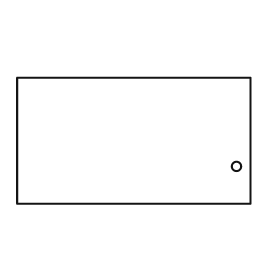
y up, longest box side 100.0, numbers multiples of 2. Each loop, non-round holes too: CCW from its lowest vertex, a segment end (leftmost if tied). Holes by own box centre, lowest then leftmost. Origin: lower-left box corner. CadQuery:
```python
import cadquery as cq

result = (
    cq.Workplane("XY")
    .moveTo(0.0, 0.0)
    .lineTo(100.0, 0.0)
    .lineTo(100.0, 54.0)
    .lineTo(0.0, 54.0)
    .close()
    .moveTo(94.0, 16.0)
    .circle(2.0)
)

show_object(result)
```